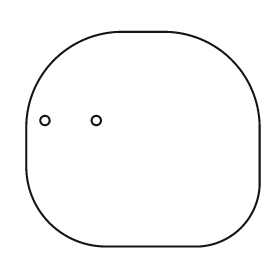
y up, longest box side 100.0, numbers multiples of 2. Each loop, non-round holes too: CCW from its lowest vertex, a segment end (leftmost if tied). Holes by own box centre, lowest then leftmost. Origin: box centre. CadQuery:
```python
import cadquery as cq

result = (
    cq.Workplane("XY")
    .moveTo(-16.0, -46.0)
    .lineTo(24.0, -46.0)
    .threePointArc((42.0, -38.0), (50.0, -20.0))
    .lineTo(50.0, 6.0)
    .threePointArc((38.0, 34.0), (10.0, 46.0))
    .lineTo(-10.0, 46.0)
    .threePointArc((-38.0, 34.0), (-50.0, 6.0))
    .lineTo(-50.0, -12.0)
    .threePointArc((-40.0, -36.0), (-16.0, -46.0))
    .close()
    .moveTo(-42.0, 8.0)
    .circle(2.0)
    .moveTo(-20.0, 8.0)
    .circle(2.0)
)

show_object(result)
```